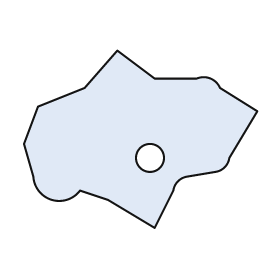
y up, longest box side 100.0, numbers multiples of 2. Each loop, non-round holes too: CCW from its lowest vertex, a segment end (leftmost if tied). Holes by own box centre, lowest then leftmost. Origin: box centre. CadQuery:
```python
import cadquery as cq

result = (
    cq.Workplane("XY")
    .moveTo(6.0, -38.0)
    .lineTo(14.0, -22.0)
    .threePointArc((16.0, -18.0), (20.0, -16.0))
    .lineTo(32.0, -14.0)
    .threePointArc((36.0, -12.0), (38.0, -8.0))
    .lineTo(50.0, 12.0)
    .lineTo(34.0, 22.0)
    .threePointArc((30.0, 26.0), (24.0, 26.0))
    .lineTo(6.0, 26.0)
    .lineTo(-10.0, 38.0)
    .lineTo(-24.0, 22.0)
    .lineTo(-44.0, 14.0)
    .lineTo(-50.0, -2.0)
    .lineTo(-46.0, -16.0)
    .threePointArc((-38.0, -26.0), (-26.0, -22.0))
    .lineTo(-14.0, -26.0)
    .close()
    .moveTo(4.0, -8.0)
    .circle(6.0)
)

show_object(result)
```